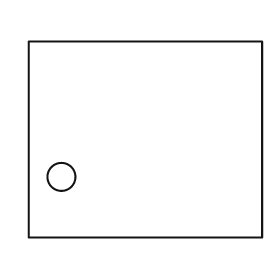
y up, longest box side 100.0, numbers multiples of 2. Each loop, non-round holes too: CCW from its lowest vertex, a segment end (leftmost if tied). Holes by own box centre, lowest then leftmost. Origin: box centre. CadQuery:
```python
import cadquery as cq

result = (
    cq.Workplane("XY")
    .moveTo(-50.0, -42.0)
    .lineTo(50.0, -42.0)
    .lineTo(50.0, 42.0)
    .lineTo(-50.0, 42.0)
    .close()
    .moveTo(-36.0, -16.0)
    .circle(6.0)
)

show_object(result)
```